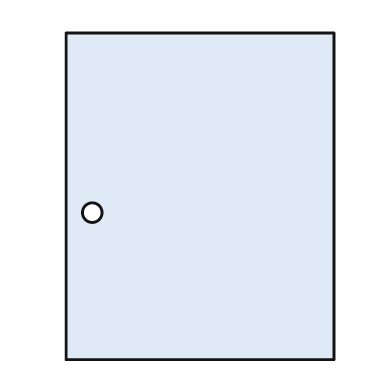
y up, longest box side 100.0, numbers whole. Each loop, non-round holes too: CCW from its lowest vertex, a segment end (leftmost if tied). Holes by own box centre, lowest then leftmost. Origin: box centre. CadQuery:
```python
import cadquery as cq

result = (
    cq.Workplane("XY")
    .moveTo(-41.0, -50.0)
    .lineTo(41.0, -50.0)
    .lineTo(41.0, 50.0)
    .lineTo(-41.0, 50.0)
    .close()
    .moveTo(-33.0, -5.0)
    .circle(3.0)
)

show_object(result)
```